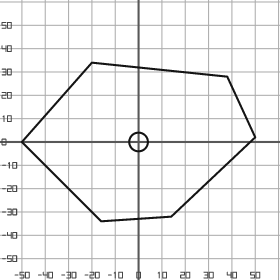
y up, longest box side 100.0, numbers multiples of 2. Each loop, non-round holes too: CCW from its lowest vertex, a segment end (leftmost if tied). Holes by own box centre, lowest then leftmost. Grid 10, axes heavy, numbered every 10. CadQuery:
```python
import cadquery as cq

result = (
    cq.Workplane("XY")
    .moveTo(-16.0, -34.0)
    .lineTo(14.0, -32.0)
    .lineTo(50.0, 2.0)
    .lineTo(38.0, 28.0)
    .lineTo(-20.0, 34.0)
    .lineTo(-50.0, 0.0)
    .close()
    .moveTo(0.0, 0.0)
    .circle(4.0)
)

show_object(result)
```